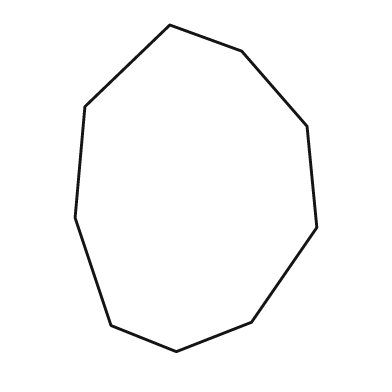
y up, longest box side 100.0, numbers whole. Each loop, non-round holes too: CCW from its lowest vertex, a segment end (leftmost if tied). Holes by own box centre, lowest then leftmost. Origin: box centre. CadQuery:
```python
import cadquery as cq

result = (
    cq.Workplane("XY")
    .moveTo(-6.0, -50.0)
    .lineTo(17.0, -41.0)
    .lineTo(37.0, -12.0)
    .lineTo(34.0, 19.0)
    .lineTo(14.0, 42.0)
    .lineTo(-8.0, 50.0)
    .lineTo(-34.0, 25.0)
    .lineTo(-37.0, -9.0)
    .lineTo(-26.0, -42.0)
    .close()
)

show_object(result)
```